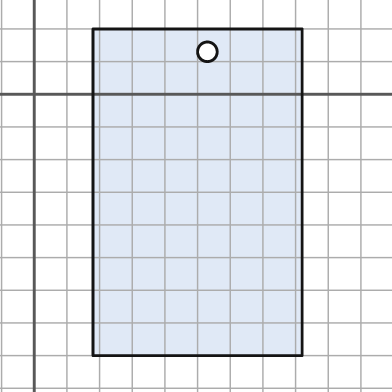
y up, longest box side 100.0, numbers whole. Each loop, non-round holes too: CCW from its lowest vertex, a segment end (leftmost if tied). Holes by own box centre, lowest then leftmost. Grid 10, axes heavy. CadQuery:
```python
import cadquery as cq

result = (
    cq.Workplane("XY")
    .moveTo(18.0, -80.0)
    .lineTo(82.0, -80.0)
    .lineTo(82.0, 20.0)
    .lineTo(18.0, 20.0)
    .close()
    .moveTo(53.0, 13.0)
    .circle(3.0)
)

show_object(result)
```